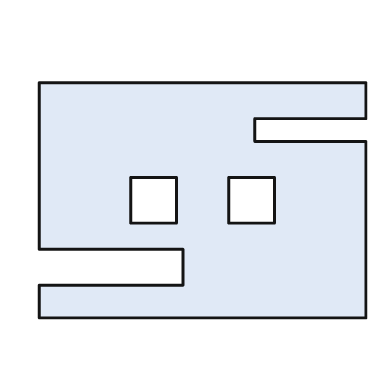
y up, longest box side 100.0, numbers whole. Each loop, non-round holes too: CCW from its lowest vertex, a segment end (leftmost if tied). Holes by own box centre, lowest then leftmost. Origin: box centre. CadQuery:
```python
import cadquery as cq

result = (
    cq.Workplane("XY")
    .moveTo(-50.0, -36.0)
    .lineTo(50.0, -36.0)
    .lineTo(50.0, 18.0)
    .lineTo(16.0, 18.0)
    .lineTo(16.0, 25.0)
    .lineTo(50.0, 25.0)
    .lineTo(50.0, 36.0)
    .lineTo(-50.0, 36.0)
    .lineTo(-50.0, -15.0)
    .lineTo(-6.0, -15.0)
    .lineTo(-6.0, -26.0)
    .lineTo(-50.0, -26.0)
    .close()
    .moveTo(-22.0, -7.0)
    .lineTo(-8.0, -7.0)
    .lineTo(-8.0, 7.0)
    .lineTo(-22.0, 7.0)
    .close()
    .moveTo(8.0, -7.0)
    .lineTo(22.0, -7.0)
    .lineTo(22.0, 7.0)
    .lineTo(8.0, 7.0)
    .close()
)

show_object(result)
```